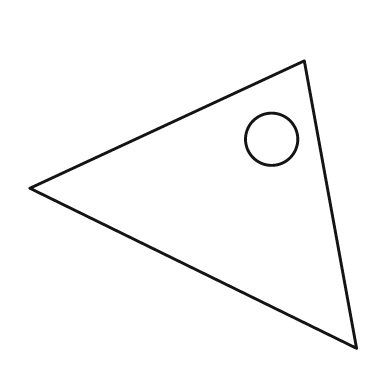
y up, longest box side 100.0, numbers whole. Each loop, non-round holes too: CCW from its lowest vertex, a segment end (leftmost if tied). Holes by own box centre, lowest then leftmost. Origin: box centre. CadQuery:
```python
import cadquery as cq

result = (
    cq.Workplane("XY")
    .moveTo(50.0, -44.0)
    .lineTo(34.0, 44.0)
    .lineTo(-50.0, 5.0)
    .close()
    .moveTo(24.0, 20.0)
    .circle(8.0)
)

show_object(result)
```